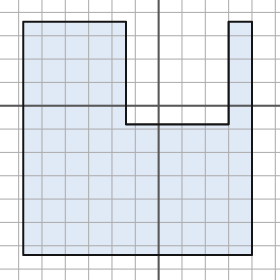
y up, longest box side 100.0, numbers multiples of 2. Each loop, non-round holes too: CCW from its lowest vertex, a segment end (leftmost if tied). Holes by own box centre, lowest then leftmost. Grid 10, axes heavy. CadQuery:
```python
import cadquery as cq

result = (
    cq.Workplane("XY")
    .moveTo(-58.0, -64.0)
    .lineTo(40.0, -64.0)
    .lineTo(40.0, 36.0)
    .lineTo(30.0, 36.0)
    .lineTo(30.0, -8.0)
    .lineTo(-14.0, -8.0)
    .lineTo(-14.0, 36.0)
    .lineTo(-58.0, 36.0)
    .close()
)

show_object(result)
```